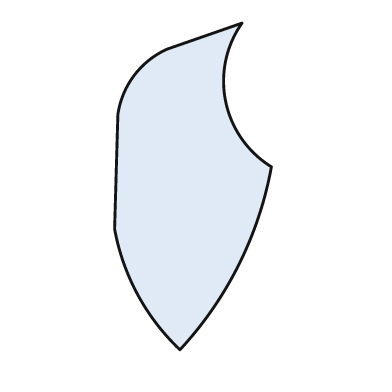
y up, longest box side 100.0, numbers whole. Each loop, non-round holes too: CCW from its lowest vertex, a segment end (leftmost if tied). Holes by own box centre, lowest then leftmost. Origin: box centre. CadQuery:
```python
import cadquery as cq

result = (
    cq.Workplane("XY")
    .moveTo(-4.0, -50.0)
    .threePointArc((14.0, -24.0), (24.0, 6.0))
    .threePointArc((10.0, 26.0), (15.0, 50.0))
    .lineTo(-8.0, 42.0)
    .threePointArc((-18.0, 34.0), (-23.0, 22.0))
    .lineTo(-24.0, -13.0)
    .threePointArc((-17.0, -33.0), (-4.0, -50.0))
    .close()
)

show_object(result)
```